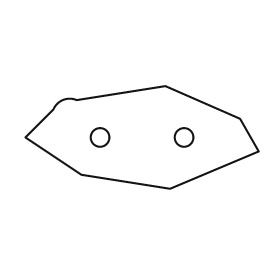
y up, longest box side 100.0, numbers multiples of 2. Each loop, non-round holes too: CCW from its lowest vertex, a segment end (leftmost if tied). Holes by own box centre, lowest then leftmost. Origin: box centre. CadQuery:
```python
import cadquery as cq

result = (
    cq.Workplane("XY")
    .moveTo(12.0, -22.0)
    .lineTo(50.0, -6.0)
    .lineTo(42.0, 8.0)
    .lineTo(10.0, 22.0)
    .lineTo(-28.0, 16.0)
    .threePointArc((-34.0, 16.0), (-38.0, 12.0))
    .lineTo(-50.0, 0.0)
    .lineTo(-26.0, -16.0)
    .close()
    .moveTo(-18.0, 0.0)
    .circle(4.0)
    .moveTo(18.0, 0.0)
    .circle(4.0)
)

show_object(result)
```